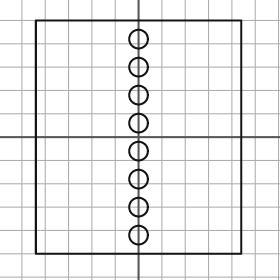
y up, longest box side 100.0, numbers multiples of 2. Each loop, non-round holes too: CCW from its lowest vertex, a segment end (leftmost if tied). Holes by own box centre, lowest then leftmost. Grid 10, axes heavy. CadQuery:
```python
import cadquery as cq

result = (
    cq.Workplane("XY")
    .moveTo(-44.0, -50.0)
    .lineTo(44.0, -50.0)
    .lineTo(44.0, 50.0)
    .lineTo(-44.0, 50.0)
    .close()
    .moveTo(0.0, -42.0)
    .circle(4.0)
    .moveTo(0.0, -30.0)
    .circle(4.0)
    .moveTo(0.0, -18.0)
    .circle(4.0)
    .moveTo(0.0, -6.0)
    .circle(4.0)
    .moveTo(0.0, 6.0)
    .circle(4.0)
    .moveTo(0.0, 18.0)
    .circle(4.0)
    .moveTo(0.0, 30.0)
    .circle(4.0)
    .moveTo(0.0, 42.0)
    .circle(4.0)
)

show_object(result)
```